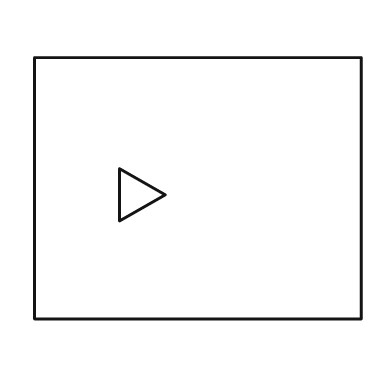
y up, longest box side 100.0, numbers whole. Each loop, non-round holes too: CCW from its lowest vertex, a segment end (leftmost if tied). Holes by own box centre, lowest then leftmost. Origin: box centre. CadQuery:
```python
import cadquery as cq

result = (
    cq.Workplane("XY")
    .moveTo(-50.0, -40.0)
    .lineTo(50.0, -40.0)
    .lineTo(50.0, 40.0)
    .lineTo(-50.0, 40.0)
    .close()
    .moveTo(-24.0, -10.0)
    .lineTo(-10.0, -2.0)
    .lineTo(-24.0, 6.0)
    .close()
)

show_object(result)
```